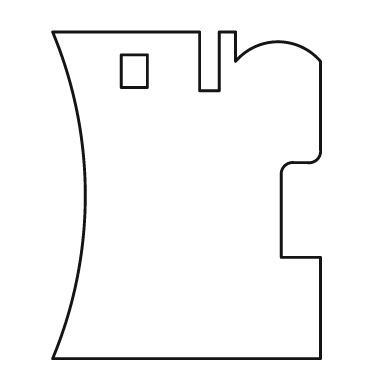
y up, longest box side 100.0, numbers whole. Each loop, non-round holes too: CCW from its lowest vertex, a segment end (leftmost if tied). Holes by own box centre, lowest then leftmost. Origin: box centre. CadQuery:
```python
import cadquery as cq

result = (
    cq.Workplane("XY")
    .moveTo(-41.0, -50.0)
    .lineTo(41.0, -50.0)
    .lineTo(41.0, -19.0)
    .lineTo(29.0, -19.0)
    .lineTo(29.0, 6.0)
    .threePointArc((30.0, 9.0), (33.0, 10.0))
    .lineTo(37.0, 10.0)
    .threePointArc((40.0, 11.0), (41.0, 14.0))
    .lineTo(41.0, 41.0)
    .threePointArc((28.0, 47.0), (15.0, 41.0))
    .lineTo(15.0, 50.0)
    .lineTo(10.0, 50.0)
    .lineTo(10.0, 32.0)
    .lineTo(4.0, 32.0)
    .lineTo(4.0, 50.0)
    .lineTo(-41.0, 50.0)
    .threePointArc((-31.0, 0.0), (-41.0, -50.0))
    .close()
    .moveTo(-20.0, 33.0)
    .lineTo(-12.0, 33.0)
    .lineTo(-12.0, 43.0)
    .lineTo(-20.0, 43.0)
    .close()
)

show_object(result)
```